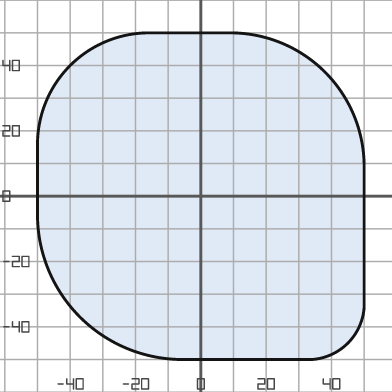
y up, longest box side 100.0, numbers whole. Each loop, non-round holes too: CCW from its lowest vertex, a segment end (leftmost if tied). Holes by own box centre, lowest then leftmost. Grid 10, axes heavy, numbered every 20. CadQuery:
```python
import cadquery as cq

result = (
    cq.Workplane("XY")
    .moveTo(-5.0, -50.0)
    .lineTo(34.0, -50.0)
    .threePointArc((45.0, -45.0), (50.0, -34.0))
    .lineTo(50.0, 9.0)
    .threePointArc((38.0, 38.0), (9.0, 50.0))
    .lineTo(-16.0, 50.0)
    .threePointArc((-40.0, 40.0), (-50.0, 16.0))
    .lineTo(-50.0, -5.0)
    .threePointArc((-37.0, -37.0), (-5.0, -50.0))
    .close()
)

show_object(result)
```